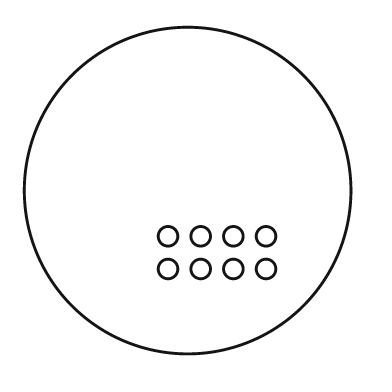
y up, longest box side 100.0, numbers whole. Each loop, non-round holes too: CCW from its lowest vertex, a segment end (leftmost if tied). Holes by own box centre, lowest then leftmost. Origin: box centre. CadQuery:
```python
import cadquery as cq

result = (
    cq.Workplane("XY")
    .moveTo(0.0, 0.0)
    .circle(50.0)
    .moveTo(-6.0, -24.0)
    .circle(3.0)
    .moveTo(4.0, -24.0)
    .circle(3.0)
    .moveTo(14.0, -24.0)
    .circle(3.0)
    .moveTo(24.0, -24.0)
    .circle(3.0)
    .moveTo(-6.0, -14.0)
    .circle(3.0)
    .moveTo(4.0, -14.0)
    .circle(3.0)
    .moveTo(14.0, -14.0)
    .circle(3.0)
    .moveTo(24.0, -14.0)
    .circle(3.0)
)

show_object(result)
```